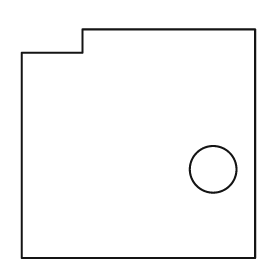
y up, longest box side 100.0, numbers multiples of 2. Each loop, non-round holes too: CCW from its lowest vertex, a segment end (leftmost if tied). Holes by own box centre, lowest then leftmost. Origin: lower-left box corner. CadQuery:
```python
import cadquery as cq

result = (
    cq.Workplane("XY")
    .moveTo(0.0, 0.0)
    .lineTo(100.0, 0.0)
    .lineTo(100.0, 98.0)
    .lineTo(26.0, 98.0)
    .lineTo(26.0, 88.0)
    .lineTo(0.0, 88.0)
    .close()
    .moveTo(82.0, 38.0)
    .circle(10.0)
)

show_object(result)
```